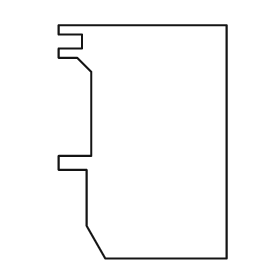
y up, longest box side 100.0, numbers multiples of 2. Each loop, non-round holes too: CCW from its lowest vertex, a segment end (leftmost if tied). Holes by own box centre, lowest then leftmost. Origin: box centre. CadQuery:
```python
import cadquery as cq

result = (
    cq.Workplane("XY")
    .moveTo(-16.0, -50.0)
    .lineTo(36.0, -50.0)
    .lineTo(36.0, 50.0)
    .lineTo(-36.0, 50.0)
    .lineTo(-36.0, 46.0)
    .lineTo(-26.0, 46.0)
    .lineTo(-26.0, 40.0)
    .lineTo(-36.0, 40.0)
    .lineTo(-36.0, 36.0)
    .lineTo(-28.0, 36.0)
    .lineTo(-22.0, 30.0)
    .lineTo(-22.0, -6.0)
    .lineTo(-36.0, -6.0)
    .lineTo(-36.0, -12.0)
    .lineTo(-24.0, -12.0)
    .lineTo(-24.0, -36.0)
    .close()
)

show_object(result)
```